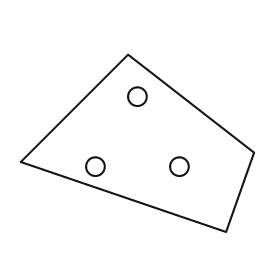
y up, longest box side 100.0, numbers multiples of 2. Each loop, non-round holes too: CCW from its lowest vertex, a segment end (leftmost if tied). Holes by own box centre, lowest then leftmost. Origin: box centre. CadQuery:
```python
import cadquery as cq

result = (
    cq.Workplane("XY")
    .moveTo(38.0, -38.0)
    .lineTo(50.0, -4.0)
    .lineTo(-4.0, 38.0)
    .lineTo(-50.0, -8.0)
    .close()
    .moveTo(-18.0, -10.0)
    .circle(4.0)
    .moveTo(18.0, -10.0)
    .circle(4.0)
    .moveTo(0.0, 20.0)
    .circle(4.0)
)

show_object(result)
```